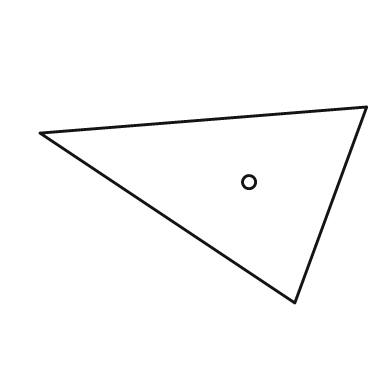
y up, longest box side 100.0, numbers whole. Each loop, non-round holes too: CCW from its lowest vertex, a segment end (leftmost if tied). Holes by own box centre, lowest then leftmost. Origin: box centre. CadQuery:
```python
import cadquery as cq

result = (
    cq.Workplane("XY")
    .moveTo(28.0, -30.0)
    .lineTo(50.0, 30.0)
    .lineTo(-50.0, 22.0)
    .close()
    .moveTo(14.0, 7.0)
    .circle(2.0)
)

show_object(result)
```